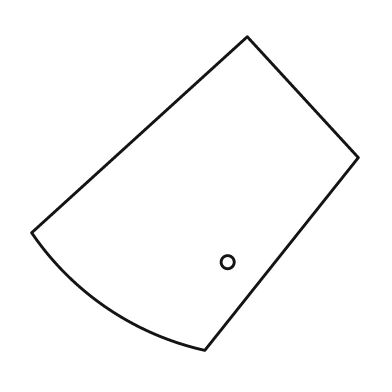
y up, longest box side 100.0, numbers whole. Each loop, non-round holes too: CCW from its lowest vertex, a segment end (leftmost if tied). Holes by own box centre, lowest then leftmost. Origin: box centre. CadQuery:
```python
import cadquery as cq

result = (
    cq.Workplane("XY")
    .moveTo(3.0, -48.0)
    .lineTo(50.0, 11.0)
    .lineTo(16.0, 48.0)
    .lineTo(-50.0, -12.0)
    .threePointArc((-27.0, -35.0), (3.0, -48.0))
    .close()
    .moveTo(10.0, -21.0)
    .circle(2.0)
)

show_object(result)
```